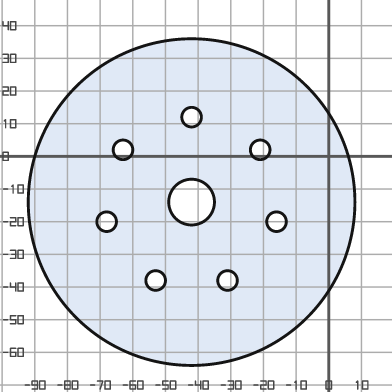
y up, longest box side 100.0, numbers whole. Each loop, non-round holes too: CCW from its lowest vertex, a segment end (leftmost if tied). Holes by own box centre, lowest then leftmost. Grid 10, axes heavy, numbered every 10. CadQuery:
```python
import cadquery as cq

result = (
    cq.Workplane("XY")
    .moveTo(-42.0, -14.0)
    .circle(50.0)
    .moveTo(-53.0, -38.0)
    .circle(3.0)
    .moveTo(-31.0, -38.0)
    .circle(3.0)
    .moveTo(-68.0, -20.0)
    .circle(3.0)
    .moveTo(-16.0, -20.0)
    .circle(3.0)
    .moveTo(-42.0, -14.0)
    .circle(7.0)
    .moveTo(-63.0, 2.0)
    .circle(3.0)
    .moveTo(-21.0, 2.0)
    .circle(3.0)
    .moveTo(-42.0, 12.0)
    .circle(3.0)
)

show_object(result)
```